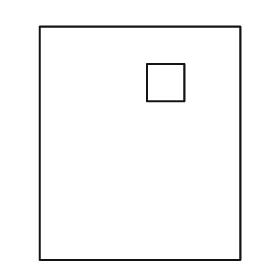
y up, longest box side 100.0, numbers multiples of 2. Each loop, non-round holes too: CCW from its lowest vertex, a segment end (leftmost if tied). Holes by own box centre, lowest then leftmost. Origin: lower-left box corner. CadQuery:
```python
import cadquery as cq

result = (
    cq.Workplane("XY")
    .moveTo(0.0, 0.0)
    .lineTo(86.0, 0.0)
    .lineTo(86.0, 100.0)
    .lineTo(0.0, 100.0)
    .close()
    .moveTo(46.0, 68.0)
    .lineTo(62.0, 68.0)
    .lineTo(62.0, 84.0)
    .lineTo(46.0, 84.0)
    .close()
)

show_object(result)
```